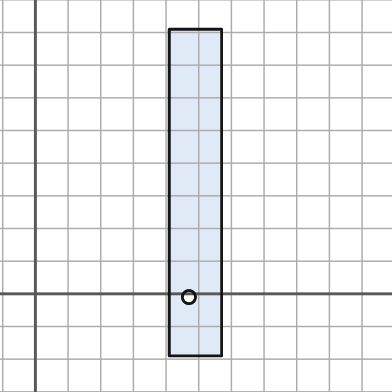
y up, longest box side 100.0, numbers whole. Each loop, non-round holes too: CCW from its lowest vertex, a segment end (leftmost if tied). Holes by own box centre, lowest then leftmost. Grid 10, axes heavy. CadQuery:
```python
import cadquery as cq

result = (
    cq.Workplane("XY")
    .moveTo(41.0, -19.0)
    .lineTo(57.0, -19.0)
    .lineTo(57.0, 81.0)
    .lineTo(41.0, 81.0)
    .close()
    .moveTo(47.0, -1.0)
    .circle(2.0)
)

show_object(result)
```